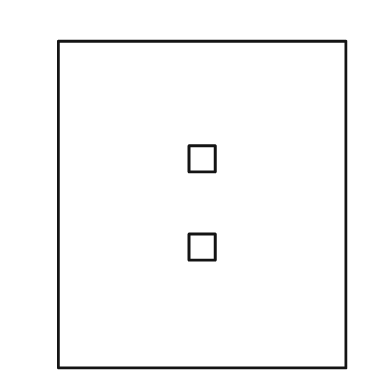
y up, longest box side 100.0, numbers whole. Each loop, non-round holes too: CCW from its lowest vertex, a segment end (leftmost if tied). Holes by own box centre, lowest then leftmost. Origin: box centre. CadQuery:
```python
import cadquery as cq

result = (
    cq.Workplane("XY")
    .moveTo(-44.0, -50.0)
    .lineTo(44.0, -50.0)
    .lineTo(44.0, 50.0)
    .lineTo(-44.0, 50.0)
    .close()
    .moveTo(-4.0, -17.0)
    .lineTo(4.0, -17.0)
    .lineTo(4.0, -9.0)
    .lineTo(-4.0, -9.0)
    .close()
    .moveTo(-4.0, 10.0)
    .lineTo(4.0, 10.0)
    .lineTo(4.0, 18.0)
    .lineTo(-4.0, 18.0)
    .close()
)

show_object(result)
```